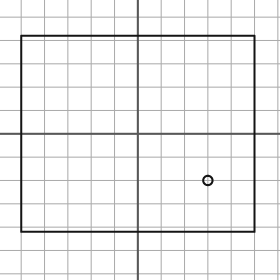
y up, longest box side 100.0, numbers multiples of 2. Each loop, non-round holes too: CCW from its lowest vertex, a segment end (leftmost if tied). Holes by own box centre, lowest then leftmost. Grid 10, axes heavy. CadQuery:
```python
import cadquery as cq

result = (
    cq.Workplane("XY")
    .moveTo(-50.0, -42.0)
    .lineTo(50.0, -42.0)
    .lineTo(50.0, 42.0)
    .lineTo(-50.0, 42.0)
    .close()
    .moveTo(30.0, -20.0)
    .circle(2.0)
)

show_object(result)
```